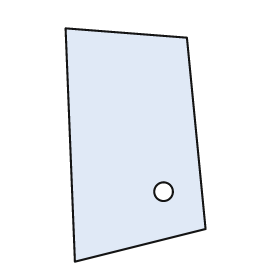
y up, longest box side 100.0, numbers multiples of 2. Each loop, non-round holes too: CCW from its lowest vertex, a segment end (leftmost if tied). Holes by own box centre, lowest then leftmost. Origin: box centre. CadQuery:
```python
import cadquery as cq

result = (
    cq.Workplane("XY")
    .moveTo(-26.0, -50.0)
    .lineTo(30.0, -36.0)
    .lineTo(22.0, 46.0)
    .lineTo(-30.0, 50.0)
    .close()
    .moveTo(12.0, -20.0)
    .circle(4.0)
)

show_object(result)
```